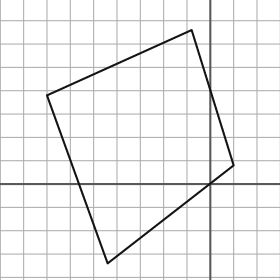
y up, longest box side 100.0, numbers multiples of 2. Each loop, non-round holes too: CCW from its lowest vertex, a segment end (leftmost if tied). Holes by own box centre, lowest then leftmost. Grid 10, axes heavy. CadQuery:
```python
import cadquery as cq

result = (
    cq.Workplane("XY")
    .moveTo(-44.0, -34.0)
    .lineTo(10.0, 8.0)
    .lineTo(-8.0, 66.0)
    .lineTo(-70.0, 38.0)
    .close()
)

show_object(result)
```